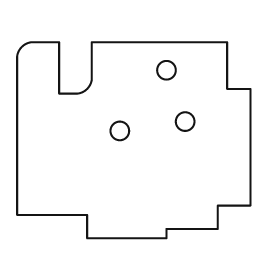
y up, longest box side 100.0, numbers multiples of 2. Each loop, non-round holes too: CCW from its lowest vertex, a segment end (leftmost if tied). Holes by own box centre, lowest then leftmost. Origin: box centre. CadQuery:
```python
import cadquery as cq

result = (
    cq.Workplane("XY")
    .moveTo(-20.0, -42.0)
    .lineTo(14.0, -42.0)
    .lineTo(14.0, -38.0)
    .lineTo(36.0, -38.0)
    .lineTo(36.0, -28.0)
    .lineTo(50.0, -28.0)
    .lineTo(50.0, 22.0)
    .lineTo(40.0, 22.0)
    .lineTo(40.0, 42.0)
    .lineTo(-18.0, 42.0)
    .lineTo(-18.0, 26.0)
    .threePointArc((-20.0, 22.0), (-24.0, 20.0))
    .lineTo(-32.0, 20.0)
    .lineTo(-32.0, 42.0)
    .lineTo(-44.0, 42.0)
    .threePointArc((-48.0, 40.0), (-50.0, 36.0))
    .lineTo(-50.0, -32.0)
    .lineTo(-20.0, -32.0)
    .close()
    .moveTo(-6.0, 4.0)
    .circle(4.0)
    .moveTo(22.0, 8.0)
    .circle(4.0)
    .moveTo(14.0, 30.0)
    .circle(4.0)
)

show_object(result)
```